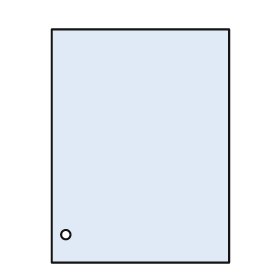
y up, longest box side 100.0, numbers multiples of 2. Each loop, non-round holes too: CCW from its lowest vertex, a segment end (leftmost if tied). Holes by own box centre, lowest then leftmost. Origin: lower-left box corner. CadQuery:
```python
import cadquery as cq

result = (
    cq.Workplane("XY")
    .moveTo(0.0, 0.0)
    .lineTo(76.0, 0.0)
    .lineTo(76.0, 100.0)
    .lineTo(0.0, 100.0)
    .close()
    .moveTo(6.0, 12.0)
    .circle(2.0)
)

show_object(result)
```